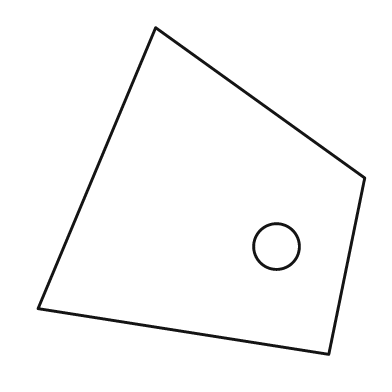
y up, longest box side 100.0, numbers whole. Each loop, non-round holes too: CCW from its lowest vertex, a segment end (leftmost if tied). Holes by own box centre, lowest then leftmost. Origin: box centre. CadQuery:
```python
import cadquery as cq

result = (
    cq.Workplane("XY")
    .moveTo(39.0, -50.0)
    .lineTo(50.0, 4.0)
    .lineTo(-14.0, 50.0)
    .lineTo(-50.0, -36.0)
    .close()
    .moveTo(23.0, -17.0)
    .circle(7.0)
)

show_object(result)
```